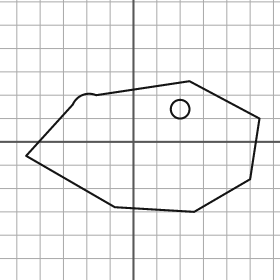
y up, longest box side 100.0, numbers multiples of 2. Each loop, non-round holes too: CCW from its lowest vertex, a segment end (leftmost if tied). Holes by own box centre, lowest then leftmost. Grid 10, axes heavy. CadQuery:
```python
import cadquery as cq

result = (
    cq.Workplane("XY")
    .moveTo(26.0, -30.0)
    .lineTo(50.0, -16.0)
    .lineTo(54.0, 10.0)
    .lineTo(24.0, 26.0)
    .lineTo(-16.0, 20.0)
    .threePointArc((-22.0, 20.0), (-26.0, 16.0))
    .lineTo(-46.0, -6.0)
    .lineTo(-8.0, -28.0)
    .close()
    .moveTo(20.0, 14.0)
    .circle(4.0)
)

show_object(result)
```